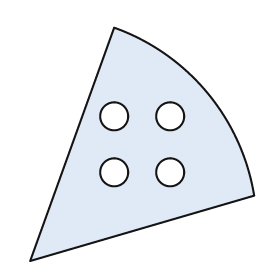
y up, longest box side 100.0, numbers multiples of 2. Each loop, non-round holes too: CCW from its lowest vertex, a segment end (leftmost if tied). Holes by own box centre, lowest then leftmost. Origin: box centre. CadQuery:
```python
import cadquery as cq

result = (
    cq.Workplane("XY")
    .moveTo(-48.0, -50.0)
    .lineTo(48.0, -22.0)
    .threePointArc((28.0, 22.0), (-12.0, 50.0))
    .close()
    .moveTo(-12.0, -12.0)
    .circle(6.0)
    .moveTo(12.0, -12.0)
    .circle(6.0)
    .moveTo(-12.0, 12.0)
    .circle(6.0)
    .moveTo(12.0, 12.0)
    .circle(6.0)
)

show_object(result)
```